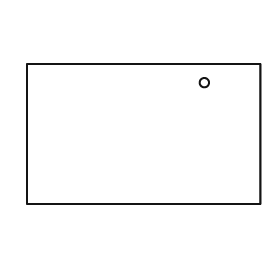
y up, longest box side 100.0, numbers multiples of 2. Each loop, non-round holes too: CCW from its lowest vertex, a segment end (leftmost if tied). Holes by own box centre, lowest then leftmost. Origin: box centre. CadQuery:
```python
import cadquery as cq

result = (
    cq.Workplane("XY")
    .moveTo(-50.0, -30.0)
    .lineTo(50.0, -30.0)
    .lineTo(50.0, 30.0)
    .lineTo(-50.0, 30.0)
    .close()
    .moveTo(26.0, 22.0)
    .circle(2.0)
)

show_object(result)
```